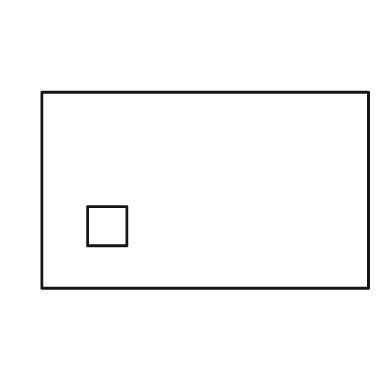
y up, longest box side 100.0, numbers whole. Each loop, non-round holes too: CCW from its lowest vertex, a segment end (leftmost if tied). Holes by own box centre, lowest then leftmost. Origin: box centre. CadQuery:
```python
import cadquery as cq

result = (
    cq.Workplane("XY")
    .moveTo(-50.0, -30.0)
    .lineTo(50.0, -30.0)
    .lineTo(50.0, 30.0)
    .lineTo(-50.0, 30.0)
    .close()
    .moveTo(-36.0, -17.0)
    .lineTo(-24.0, -17.0)
    .lineTo(-24.0, -5.0)
    .lineTo(-36.0, -5.0)
    .close()
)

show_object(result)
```